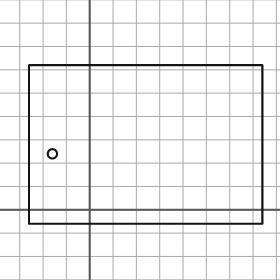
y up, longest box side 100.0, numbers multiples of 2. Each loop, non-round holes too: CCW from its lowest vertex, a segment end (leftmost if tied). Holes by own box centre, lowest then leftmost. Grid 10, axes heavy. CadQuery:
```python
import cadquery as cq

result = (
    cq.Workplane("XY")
    .moveTo(-26.0, -6.0)
    .lineTo(74.0, -6.0)
    .lineTo(74.0, 62.0)
    .lineTo(-26.0, 62.0)
    .close()
    .moveTo(-16.0, 24.0)
    .circle(2.0)
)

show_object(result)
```